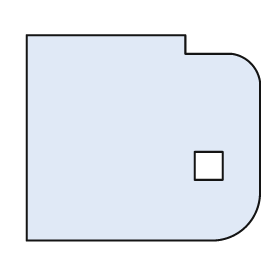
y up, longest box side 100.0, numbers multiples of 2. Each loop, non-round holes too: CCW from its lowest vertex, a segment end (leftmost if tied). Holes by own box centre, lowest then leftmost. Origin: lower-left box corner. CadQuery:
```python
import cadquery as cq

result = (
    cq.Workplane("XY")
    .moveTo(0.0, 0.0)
    .lineTo(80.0, 0.0)
    .threePointArc((94.0, 6.0), (100.0, 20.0))
    .lineTo(100.0, 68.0)
    .threePointArc((96.0, 76.0), (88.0, 80.0))
    .lineTo(68.0, 80.0)
    .lineTo(68.0, 88.0)
    .lineTo(0.0, 88.0)
    .close()
    .moveTo(72.0, 26.0)
    .lineTo(84.0, 26.0)
    .lineTo(84.0, 38.0)
    .lineTo(72.0, 38.0)
    .close()
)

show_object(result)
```